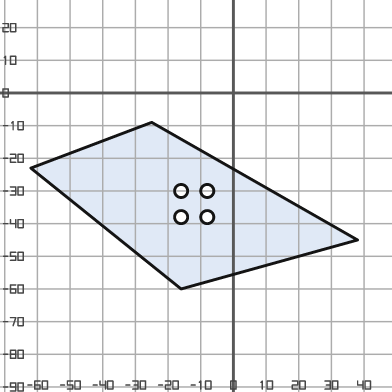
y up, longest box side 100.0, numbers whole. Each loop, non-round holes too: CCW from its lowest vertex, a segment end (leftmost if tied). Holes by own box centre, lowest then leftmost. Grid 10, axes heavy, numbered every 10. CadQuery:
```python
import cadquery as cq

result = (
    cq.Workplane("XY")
    .moveTo(-16.0, -60.0)
    .lineTo(38.0, -45.0)
    .lineTo(-25.0, -9.0)
    .lineTo(-62.0, -23.0)
    .close()
    .moveTo(-16.0, -38.0)
    .circle(2.0)
    .moveTo(-8.0, -38.0)
    .circle(2.0)
    .moveTo(-16.0, -30.0)
    .circle(2.0)
    .moveTo(-8.0, -30.0)
    .circle(2.0)
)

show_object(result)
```